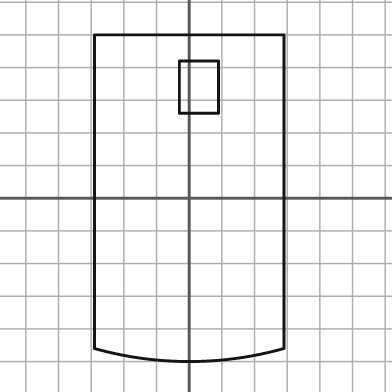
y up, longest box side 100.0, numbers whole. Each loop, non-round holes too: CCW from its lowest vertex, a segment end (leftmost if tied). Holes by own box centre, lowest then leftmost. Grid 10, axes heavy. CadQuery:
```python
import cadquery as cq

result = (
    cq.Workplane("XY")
    .moveTo(-29.0, -46.0)
    .threePointArc((0.0, -50.0), (29.0, -46.0))
    .lineTo(29.0, 50.0)
    .lineTo(-29.0, 50.0)
    .close()
    .moveTo(-3.0, 26.0)
    .lineTo(9.0, 26.0)
    .lineTo(9.0, 42.0)
    .lineTo(-3.0, 42.0)
    .close()
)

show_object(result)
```